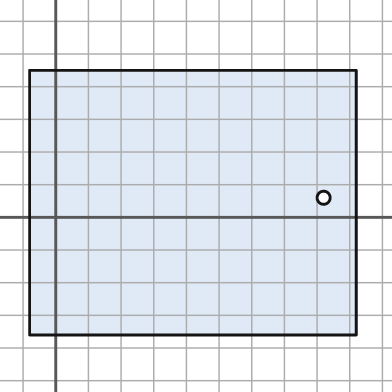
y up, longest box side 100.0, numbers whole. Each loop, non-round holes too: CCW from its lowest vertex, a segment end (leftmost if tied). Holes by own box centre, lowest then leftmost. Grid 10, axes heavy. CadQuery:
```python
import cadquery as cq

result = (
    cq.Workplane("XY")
    .moveTo(-8.0, -36.0)
    .lineTo(92.0, -36.0)
    .lineTo(92.0, 45.0)
    .lineTo(-8.0, 45.0)
    .close()
    .moveTo(82.0, 6.0)
    .circle(2.0)
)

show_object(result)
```